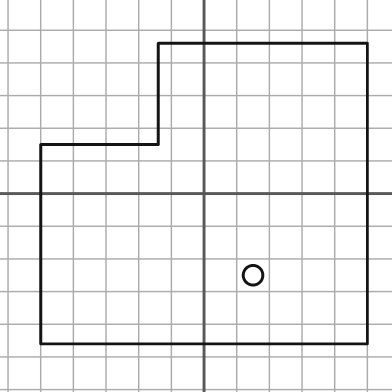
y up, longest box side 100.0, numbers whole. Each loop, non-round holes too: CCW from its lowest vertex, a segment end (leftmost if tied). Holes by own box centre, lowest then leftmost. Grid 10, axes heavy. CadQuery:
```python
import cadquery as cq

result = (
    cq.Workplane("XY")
    .moveTo(-50.0, -46.0)
    .lineTo(50.0, -46.0)
    .lineTo(50.0, 46.0)
    .lineTo(-14.0, 46.0)
    .lineTo(-14.0, 15.0)
    .lineTo(-50.0, 15.0)
    .close()
    .moveTo(15.0, -25.0)
    .circle(3.0)
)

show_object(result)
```